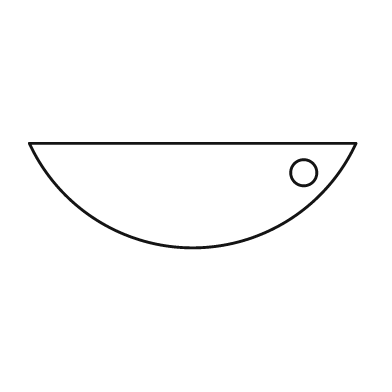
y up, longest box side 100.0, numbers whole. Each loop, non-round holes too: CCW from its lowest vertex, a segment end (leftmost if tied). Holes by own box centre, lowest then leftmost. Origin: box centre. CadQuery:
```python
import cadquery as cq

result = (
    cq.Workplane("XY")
    .moveTo(-50.0, 16.0)
    .threePointArc((0.0, -16.0), (50.0, 16.0))
    .close()
    .moveTo(34.0, 7.0)
    .circle(4.0)
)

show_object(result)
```